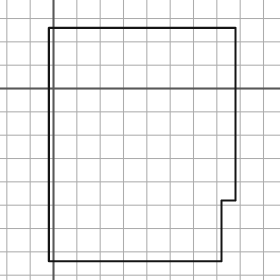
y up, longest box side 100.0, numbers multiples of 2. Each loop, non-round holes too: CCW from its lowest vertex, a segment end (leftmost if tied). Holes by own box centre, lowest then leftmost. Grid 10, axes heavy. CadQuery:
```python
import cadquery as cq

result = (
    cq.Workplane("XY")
    .moveTo(-2.0, -74.0)
    .lineTo(72.0, -74.0)
    .lineTo(72.0, -48.0)
    .lineTo(78.0, -48.0)
    .lineTo(78.0, 26.0)
    .lineTo(-2.0, 26.0)
    .close()
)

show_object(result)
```